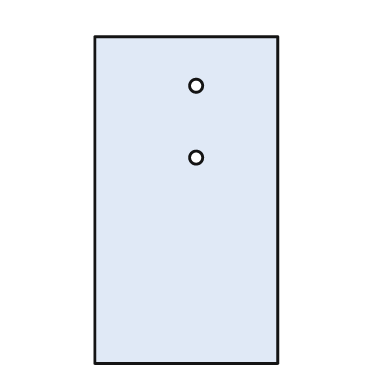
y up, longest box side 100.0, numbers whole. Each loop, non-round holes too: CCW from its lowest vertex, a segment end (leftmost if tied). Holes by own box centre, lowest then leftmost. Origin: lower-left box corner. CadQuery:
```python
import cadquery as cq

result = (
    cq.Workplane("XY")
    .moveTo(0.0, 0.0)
    .lineTo(56.0, 0.0)
    .lineTo(56.0, 100.0)
    .lineTo(0.0, 100.0)
    .close()
    .moveTo(31.0, 63.0)
    .circle(2.0)
    .moveTo(31.0, 85.0)
    .circle(2.0)
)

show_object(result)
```